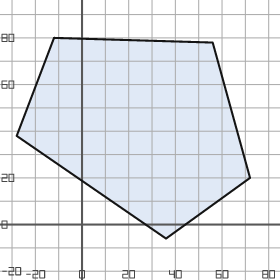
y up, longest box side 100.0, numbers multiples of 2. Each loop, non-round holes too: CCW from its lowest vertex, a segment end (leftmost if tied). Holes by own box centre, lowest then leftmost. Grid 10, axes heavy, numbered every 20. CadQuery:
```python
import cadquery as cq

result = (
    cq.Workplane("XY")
    .moveTo(36.0, -6.0)
    .lineTo(72.0, 20.0)
    .lineTo(56.0, 78.0)
    .lineTo(-12.0, 80.0)
    .lineTo(-28.0, 38.0)
    .close()
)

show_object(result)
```